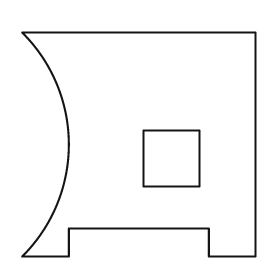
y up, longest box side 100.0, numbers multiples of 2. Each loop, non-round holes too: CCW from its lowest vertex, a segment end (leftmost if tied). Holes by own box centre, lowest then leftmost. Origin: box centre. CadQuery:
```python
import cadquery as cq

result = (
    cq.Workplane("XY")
    .moveTo(-50.0, -48.0)
    .lineTo(-30.0, -48.0)
    .lineTo(-30.0, -36.0)
    .lineTo(30.0, -36.0)
    .lineTo(30.0, -48.0)
    .lineTo(50.0, -48.0)
    .lineTo(50.0, 48.0)
    .lineTo(-50.0, 48.0)
    .threePointArc((-30.0, 0.0), (-50.0, -48.0))
    .close()
    .moveTo(2.0, -18.0)
    .lineTo(26.0, -18.0)
    .lineTo(26.0, 6.0)
    .lineTo(2.0, 6.0)
    .close()
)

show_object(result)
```